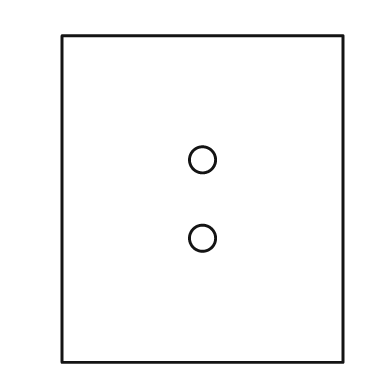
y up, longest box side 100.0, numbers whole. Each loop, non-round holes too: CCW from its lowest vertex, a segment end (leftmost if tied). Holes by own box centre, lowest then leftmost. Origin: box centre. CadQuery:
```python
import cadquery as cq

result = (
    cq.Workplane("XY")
    .moveTo(-43.0, -50.0)
    .lineTo(43.0, -50.0)
    .lineTo(43.0, 50.0)
    .lineTo(-43.0, 50.0)
    .close()
    .moveTo(0.0, -12.0)
    .circle(4.0)
    .moveTo(0.0, 12.0)
    .circle(4.0)
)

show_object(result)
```